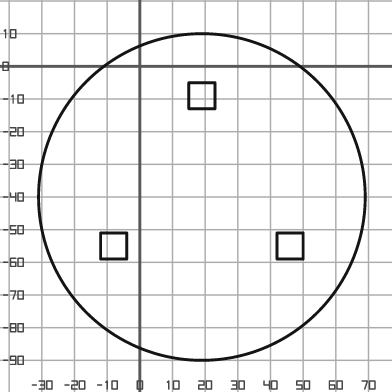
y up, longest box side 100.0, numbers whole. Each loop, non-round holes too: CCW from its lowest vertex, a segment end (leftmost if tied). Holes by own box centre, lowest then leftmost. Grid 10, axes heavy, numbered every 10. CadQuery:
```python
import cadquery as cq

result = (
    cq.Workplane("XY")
    .moveTo(19.0, -40.0)
    .circle(50.0)
    .moveTo(-12.0, -59.0)
    .lineTo(-4.0, -59.0)
    .lineTo(-4.0, -51.0)
    .lineTo(-12.0, -51.0)
    .close()
    .moveTo(42.0, -59.0)
    .lineTo(50.0, -59.0)
    .lineTo(50.0, -51.0)
    .lineTo(42.0, -51.0)
    .close()
    .moveTo(15.0, -13.0)
    .lineTo(23.0, -13.0)
    .lineTo(23.0, -5.0)
    .lineTo(15.0, -5.0)
    .close()
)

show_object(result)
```